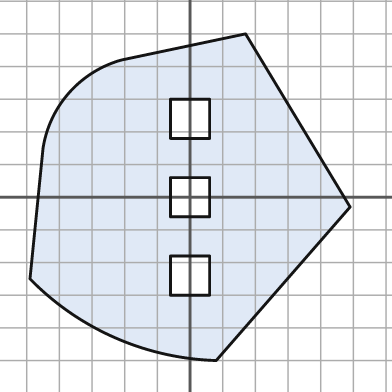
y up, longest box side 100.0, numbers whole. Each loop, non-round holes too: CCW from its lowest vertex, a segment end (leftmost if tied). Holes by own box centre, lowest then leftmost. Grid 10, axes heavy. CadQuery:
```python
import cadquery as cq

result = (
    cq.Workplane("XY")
    .moveTo(8.0, -50.0)
    .lineTo(49.0, -3.0)
    .lineTo(17.0, 50.0)
    .lineTo(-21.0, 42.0)
    .threePointArc((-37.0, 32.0), (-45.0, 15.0))
    .lineTo(-49.0, -25.0)
    .threePointArc((-23.0, -43.0), (8.0, -50.0))
    .close()
    .moveTo(-6.0, -30.0)
    .lineTo(6.0, -30.0)
    .lineTo(6.0, -18.0)
    .lineTo(-6.0, -18.0)
    .close()
    .moveTo(-6.0, -6.0)
    .lineTo(6.0, -6.0)
    .lineTo(6.0, 6.0)
    .lineTo(-6.0, 6.0)
    .close()
    .moveTo(-6.0, 18.0)
    .lineTo(6.0, 18.0)
    .lineTo(6.0, 30.0)
    .lineTo(-6.0, 30.0)
    .close()
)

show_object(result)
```